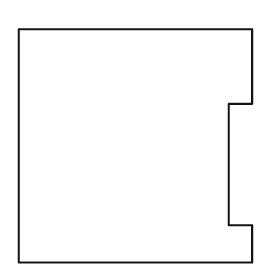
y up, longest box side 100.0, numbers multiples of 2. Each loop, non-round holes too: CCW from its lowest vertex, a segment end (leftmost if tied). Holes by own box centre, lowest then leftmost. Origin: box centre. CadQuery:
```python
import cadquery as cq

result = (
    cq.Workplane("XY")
    .moveTo(-50.0, -50.0)
    .lineTo(50.0, -50.0)
    .lineTo(50.0, -34.0)
    .lineTo(40.0, -34.0)
    .lineTo(40.0, 18.0)
    .lineTo(50.0, 18.0)
    .lineTo(50.0, 50.0)
    .lineTo(-50.0, 50.0)
    .close()
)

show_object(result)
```